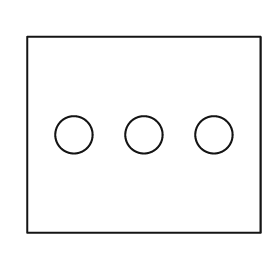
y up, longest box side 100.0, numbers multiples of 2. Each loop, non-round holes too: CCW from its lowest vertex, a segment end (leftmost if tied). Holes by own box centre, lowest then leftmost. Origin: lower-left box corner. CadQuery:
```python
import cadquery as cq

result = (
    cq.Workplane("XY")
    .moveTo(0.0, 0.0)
    .lineTo(100.0, 0.0)
    .lineTo(100.0, 84.0)
    .lineTo(0.0, 84.0)
    .close()
    .moveTo(20.0, 42.0)
    .circle(8.0)
    .moveTo(50.0, 42.0)
    .circle(8.0)
    .moveTo(80.0, 42.0)
    .circle(8.0)
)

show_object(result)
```